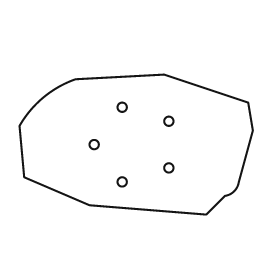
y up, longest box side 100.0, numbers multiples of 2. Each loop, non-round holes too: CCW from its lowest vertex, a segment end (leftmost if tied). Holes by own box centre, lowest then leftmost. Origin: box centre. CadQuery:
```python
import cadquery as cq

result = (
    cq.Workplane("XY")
    .moveTo(30.0, -30.0)
    .lineTo(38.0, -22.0)
    .threePointArc((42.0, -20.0), (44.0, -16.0))
    .lineTo(50.0, 6.0)
    .lineTo(48.0, 18.0)
    .lineTo(12.0, 30.0)
    .lineTo(-26.0, 28.0)
    .threePointArc((-40.0, 20.0), (-50.0, 8.0))
    .lineTo(-48.0, -14.0)
    .lineTo(-20.0, -26.0)
    .close()
    .moveTo(-6.0, -16.0)
    .circle(2.0)
    .moveTo(14.0, -10.0)
    .circle(2.0)
    .moveTo(-18.0, 0.0)
    .circle(2.0)
    .moveTo(14.0, 10.0)
    .circle(2.0)
    .moveTo(-6.0, 16.0)
    .circle(2.0)
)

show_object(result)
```